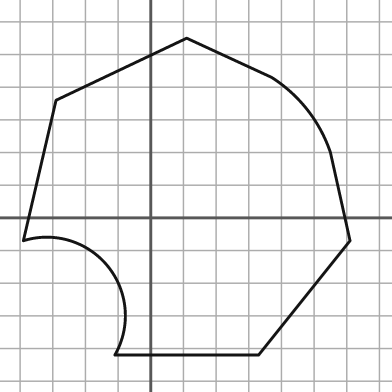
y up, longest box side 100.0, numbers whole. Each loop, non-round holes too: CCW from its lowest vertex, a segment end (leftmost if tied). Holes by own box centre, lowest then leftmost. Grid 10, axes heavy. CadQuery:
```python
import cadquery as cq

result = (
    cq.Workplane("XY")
    .moveTo(-11.0, -42.0)
    .lineTo(33.0, -42.0)
    .lineTo(61.0, -7.0)
    .lineTo(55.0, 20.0)
    .threePointArc((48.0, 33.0), (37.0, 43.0))
    .lineTo(11.0, 55.0)
    .lineTo(-29.0, 36.0)
    .lineTo(-39.0, -7.0)
    .threePointArc((-13.0, -15.0), (-11.0, -42.0))
    .close()
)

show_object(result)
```